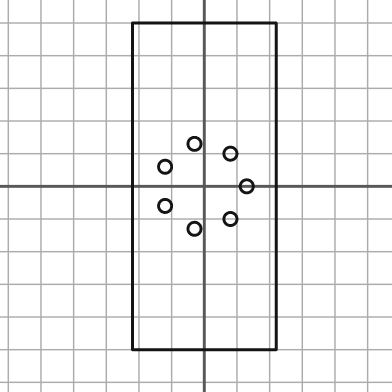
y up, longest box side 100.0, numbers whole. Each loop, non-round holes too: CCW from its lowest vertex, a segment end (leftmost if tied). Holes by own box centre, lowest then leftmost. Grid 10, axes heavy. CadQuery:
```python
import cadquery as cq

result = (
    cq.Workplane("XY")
    .moveTo(-22.0, -50.0)
    .lineTo(22.0, -50.0)
    .lineTo(22.0, 50.0)
    .lineTo(-22.0, 50.0)
    .close()
    .moveTo(-3.0, -13.0)
    .circle(2.0)
    .moveTo(8.0, -10.0)
    .circle(2.0)
    .moveTo(-12.0, -6.0)
    .circle(2.0)
    .moveTo(13.0, 0.0)
    .circle(2.0)
    .moveTo(-12.0, 6.0)
    .circle(2.0)
    .moveTo(8.0, 10.0)
    .circle(2.0)
    .moveTo(-3.0, 13.0)
    .circle(2.0)
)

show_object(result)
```